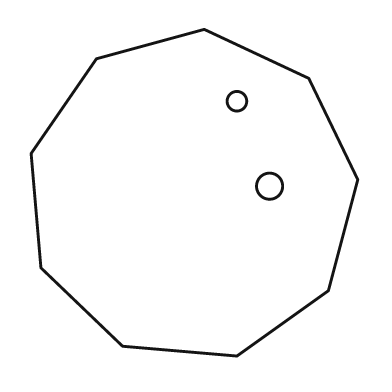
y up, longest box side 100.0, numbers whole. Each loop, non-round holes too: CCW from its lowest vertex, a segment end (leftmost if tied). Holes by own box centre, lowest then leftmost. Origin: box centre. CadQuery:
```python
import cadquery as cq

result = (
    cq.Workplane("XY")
    .moveTo(13.0, -50.0)
    .lineTo(41.0, -30.0)
    .lineTo(50.0, 4.0)
    .lineTo(35.0, 35.0)
    .lineTo(3.0, 50.0)
    .lineTo(-30.0, 41.0)
    .lineTo(-50.0, 12.0)
    .lineTo(-47.0, -23.0)
    .lineTo(-22.0, -47.0)
    .close()
    .moveTo(23.0, 2.0)
    .circle(4.0)
    .moveTo(13.0, 28.0)
    .circle(3.0)
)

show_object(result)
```